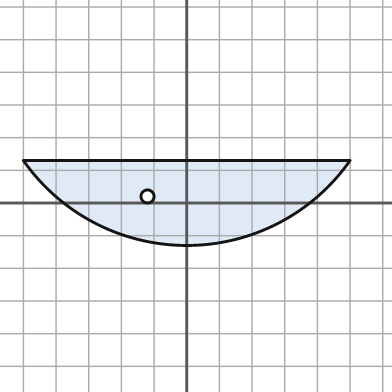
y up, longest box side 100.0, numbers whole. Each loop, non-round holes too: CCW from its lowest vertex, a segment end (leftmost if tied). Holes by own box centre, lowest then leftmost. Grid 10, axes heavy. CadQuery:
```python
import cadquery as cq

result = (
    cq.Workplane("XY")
    .moveTo(-50.0, 13.0)
    .threePointArc((0.0, -13.0), (50.0, 13.0))
    .close()
    .moveTo(-12.0, 2.0)
    .circle(2.0)
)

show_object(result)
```